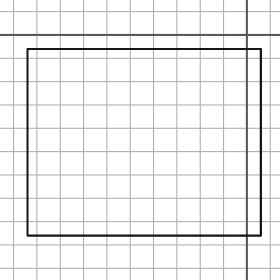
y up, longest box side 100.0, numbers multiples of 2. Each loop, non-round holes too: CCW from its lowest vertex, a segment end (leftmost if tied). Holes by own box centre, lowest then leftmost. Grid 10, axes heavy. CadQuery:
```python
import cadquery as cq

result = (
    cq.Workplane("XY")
    .moveTo(-94.0, -86.0)
    .lineTo(6.0, -86.0)
    .lineTo(6.0, -6.0)
    .lineTo(-94.0, -6.0)
    .close()
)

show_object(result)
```